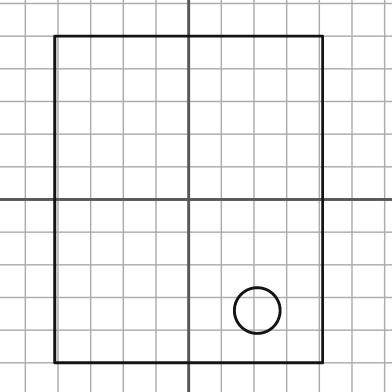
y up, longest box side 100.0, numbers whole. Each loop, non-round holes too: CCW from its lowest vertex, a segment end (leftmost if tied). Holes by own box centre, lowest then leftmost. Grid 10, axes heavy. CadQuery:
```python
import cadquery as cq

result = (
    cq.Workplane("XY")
    .moveTo(-41.0, -50.0)
    .lineTo(41.0, -50.0)
    .lineTo(41.0, 50.0)
    .lineTo(-41.0, 50.0)
    .close()
    .moveTo(21.0, -34.0)
    .circle(7.0)
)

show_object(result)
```